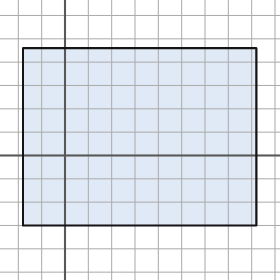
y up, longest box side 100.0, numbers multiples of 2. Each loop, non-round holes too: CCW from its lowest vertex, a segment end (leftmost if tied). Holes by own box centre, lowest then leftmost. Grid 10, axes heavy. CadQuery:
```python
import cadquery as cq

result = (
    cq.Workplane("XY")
    .moveTo(-18.0, -30.0)
    .lineTo(82.0, -30.0)
    .lineTo(82.0, 46.0)
    .lineTo(-18.0, 46.0)
    .close()
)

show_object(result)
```